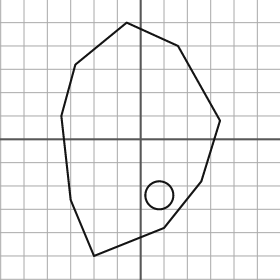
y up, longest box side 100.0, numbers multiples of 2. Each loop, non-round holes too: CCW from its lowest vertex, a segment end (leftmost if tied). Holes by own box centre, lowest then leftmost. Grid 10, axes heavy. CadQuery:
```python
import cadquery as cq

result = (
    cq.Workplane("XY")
    .moveTo(-20.0, -50.0)
    .lineTo(10.0, -38.0)
    .lineTo(26.0, -18.0)
    .lineTo(34.0, 8.0)
    .lineTo(16.0, 40.0)
    .lineTo(-6.0, 50.0)
    .lineTo(-28.0, 32.0)
    .lineTo(-34.0, 10.0)
    .lineTo(-30.0, -26.0)
    .close()
    .moveTo(8.0, -24.0)
    .circle(6.0)
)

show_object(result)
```